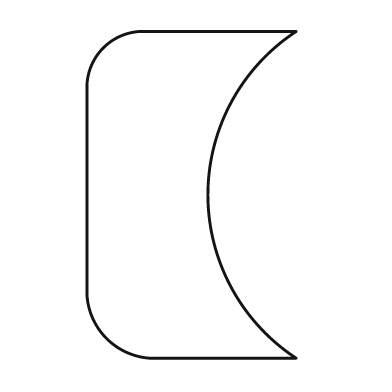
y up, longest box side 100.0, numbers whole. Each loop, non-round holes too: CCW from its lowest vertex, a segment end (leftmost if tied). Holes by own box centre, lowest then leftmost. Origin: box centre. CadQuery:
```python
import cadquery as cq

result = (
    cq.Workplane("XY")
    .moveTo(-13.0, -50.0)
    .lineTo(32.0, -50.0)
    .threePointArc((5.0, 0.0), (32.0, 50.0))
    .lineTo(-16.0, 50.0)
    .threePointArc((-27.0, 45.0), (-32.0, 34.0))
    .lineTo(-32.0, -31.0)
    .threePointArc((-26.0, -44.0), (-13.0, -50.0))
    .close()
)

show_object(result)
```